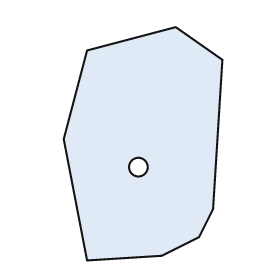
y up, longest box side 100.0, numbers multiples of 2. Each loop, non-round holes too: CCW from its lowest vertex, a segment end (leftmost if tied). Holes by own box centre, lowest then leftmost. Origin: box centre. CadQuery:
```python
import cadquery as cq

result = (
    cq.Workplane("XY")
    .moveTo(-24.0, -50.0)
    .lineTo(8.0, -48.0)
    .lineTo(24.0, -40.0)
    .lineTo(30.0, -28.0)
    .lineTo(34.0, 36.0)
    .lineTo(14.0, 50.0)
    .lineTo(-24.0, 40.0)
    .lineTo(-34.0, 2.0)
    .close()
    .moveTo(-2.0, -10.0)
    .circle(4.0)
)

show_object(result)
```